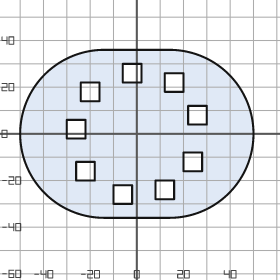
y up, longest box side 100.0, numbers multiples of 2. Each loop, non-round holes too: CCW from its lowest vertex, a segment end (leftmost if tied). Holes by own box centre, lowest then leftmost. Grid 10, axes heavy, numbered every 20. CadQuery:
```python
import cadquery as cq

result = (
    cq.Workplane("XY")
    .moveTo(-14.0, -36.0)
    .lineTo(14.0, -36.0)
    .threePointArc((50.0, 0.0), (14.0, 36.0))
    .lineTo(-14.0, 36.0)
    .threePointArc((-50.0, 0.0), (-14.0, -36.0))
    .close()
    .moveTo(-10.0, -30.0)
    .lineTo(-2.0, -30.0)
    .lineTo(-2.0, -22.0)
    .lineTo(-10.0, -22.0)
    .close()
    .moveTo(8.0, -28.0)
    .lineTo(16.0, -28.0)
    .lineTo(16.0, -20.0)
    .lineTo(8.0, -20.0)
    .close()
    .moveTo(-26.0, -20.0)
    .lineTo(-18.0, -20.0)
    .lineTo(-18.0, -12.0)
    .lineTo(-26.0, -12.0)
    .close()
    .moveTo(20.0, -16.0)
    .lineTo(28.0, -16.0)
    .lineTo(28.0, -8.0)
    .lineTo(20.0, -8.0)
    .close()
    .moveTo(-30.0, -2.0)
    .lineTo(-22.0, -2.0)
    .lineTo(-22.0, 6.0)
    .lineTo(-30.0, 6.0)
    .close()
    .moveTo(22.0, 4.0)
    .lineTo(30.0, 4.0)
    .lineTo(30.0, 12.0)
    .lineTo(22.0, 12.0)
    .close()
    .moveTo(-24.0, 14.0)
    .lineTo(-16.0, 14.0)
    .lineTo(-16.0, 22.0)
    .lineTo(-24.0, 22.0)
    .close()
    .moveTo(12.0, 18.0)
    .lineTo(20.0, 18.0)
    .lineTo(20.0, 26.0)
    .lineTo(12.0, 26.0)
    .close()
    .moveTo(-6.0, 22.0)
    .lineTo(2.0, 22.0)
    .lineTo(2.0, 30.0)
    .lineTo(-6.0, 30.0)
    .close()
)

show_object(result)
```